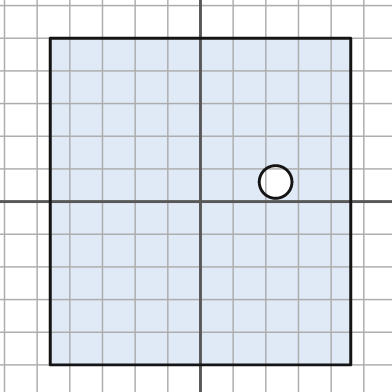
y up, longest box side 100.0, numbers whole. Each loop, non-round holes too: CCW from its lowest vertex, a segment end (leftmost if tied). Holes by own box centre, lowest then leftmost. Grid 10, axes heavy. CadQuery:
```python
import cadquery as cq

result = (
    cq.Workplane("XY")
    .moveTo(-46.0, -50.0)
    .lineTo(46.0, -50.0)
    .lineTo(46.0, 50.0)
    .lineTo(-46.0, 50.0)
    .close()
    .moveTo(23.0, 6.0)
    .circle(5.0)
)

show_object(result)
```